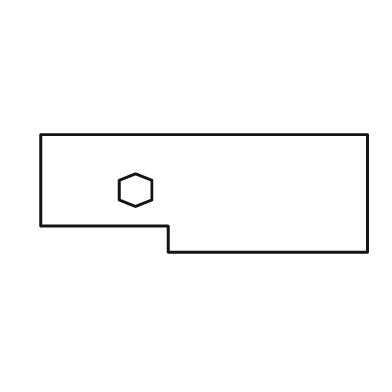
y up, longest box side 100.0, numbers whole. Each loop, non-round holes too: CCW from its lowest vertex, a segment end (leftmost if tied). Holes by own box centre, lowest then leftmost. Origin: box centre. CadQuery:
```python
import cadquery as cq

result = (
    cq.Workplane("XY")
    .moveTo(-11.0, -18.0)
    .lineTo(50.0, -18.0)
    .lineTo(50.0, 18.0)
    .lineTo(-50.0, 18.0)
    .lineTo(-50.0, -10.0)
    .lineTo(-11.0, -10.0)
    .close()
    .moveTo(-21.0, -4.0)
    .lineTo(-16.0, -2.0)
    .lineTo(-16.0, 4.0)
    .lineTo(-21.0, 6.0)
    .lineTo(-26.0, 4.0)
    .lineTo(-26.0, -2.0)
    .close()
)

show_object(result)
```